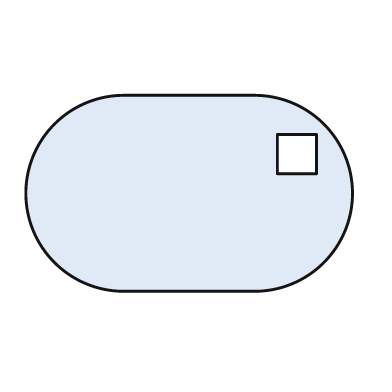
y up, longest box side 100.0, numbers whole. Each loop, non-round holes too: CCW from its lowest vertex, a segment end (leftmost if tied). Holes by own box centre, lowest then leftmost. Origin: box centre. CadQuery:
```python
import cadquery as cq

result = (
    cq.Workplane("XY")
    .moveTo(-20.0, -30.0)
    .lineTo(20.0, -30.0)
    .threePointArc((50.0, 0.0), (20.0, 30.0))
    .lineTo(-20.0, 30.0)
    .threePointArc((-50.0, 0.0), (-20.0, -30.0))
    .close()
    .moveTo(27.0, 6.0)
    .lineTo(39.0, 6.0)
    .lineTo(39.0, 18.0)
    .lineTo(27.0, 18.0)
    .close()
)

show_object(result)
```